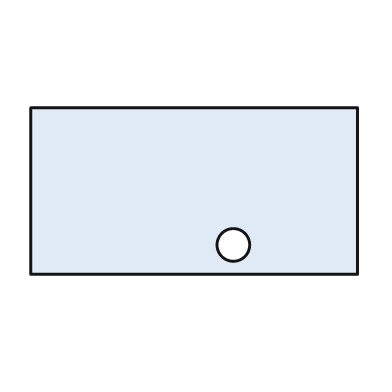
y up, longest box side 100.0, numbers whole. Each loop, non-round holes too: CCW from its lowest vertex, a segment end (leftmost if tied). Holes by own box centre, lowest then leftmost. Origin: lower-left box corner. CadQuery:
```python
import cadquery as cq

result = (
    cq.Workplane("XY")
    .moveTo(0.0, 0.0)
    .lineTo(100.0, 0.0)
    .lineTo(100.0, 51.0)
    .lineTo(0.0, 51.0)
    .close()
    .moveTo(62.0, 9.0)
    .circle(5.0)
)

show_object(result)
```